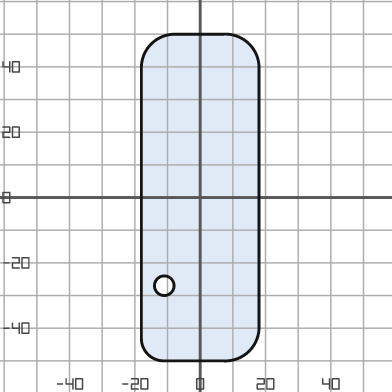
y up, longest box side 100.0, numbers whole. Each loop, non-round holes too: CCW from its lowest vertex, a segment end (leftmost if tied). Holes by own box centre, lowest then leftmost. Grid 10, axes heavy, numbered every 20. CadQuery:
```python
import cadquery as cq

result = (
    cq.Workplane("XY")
    .moveTo(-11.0, -50.0)
    .lineTo(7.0, -50.0)
    .threePointArc((15.0, -47.0), (18.0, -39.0))
    .lineTo(18.0, 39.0)
    .threePointArc((15.0, 47.0), (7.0, 50.0))
    .lineTo(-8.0, 50.0)
    .threePointArc((-15.0, 47.0), (-18.0, 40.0))
    .lineTo(-18.0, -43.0)
    .threePointArc((-16.0, -48.0), (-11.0, -50.0))
    .close()
    .moveTo(-11.0, -27.0)
    .circle(3.0)
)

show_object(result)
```